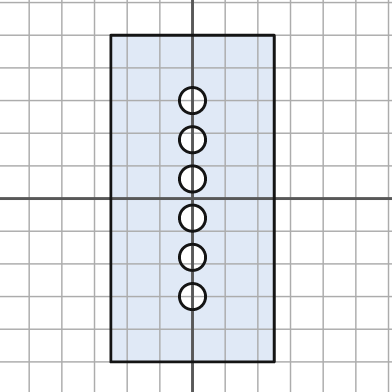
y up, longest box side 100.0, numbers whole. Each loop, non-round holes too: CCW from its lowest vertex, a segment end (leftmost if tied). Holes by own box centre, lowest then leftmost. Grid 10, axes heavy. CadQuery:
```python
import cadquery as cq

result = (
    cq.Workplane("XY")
    .moveTo(-25.0, -50.0)
    .lineTo(25.0, -50.0)
    .lineTo(25.0, 50.0)
    .lineTo(-25.0, 50.0)
    .close()
    .moveTo(0.0, -30.0)
    .circle(4.0)
    .moveTo(0.0, -18.0)
    .circle(4.0)
    .moveTo(0.0, -6.0)
    .circle(4.0)
    .moveTo(0.0, 6.0)
    .circle(4.0)
    .moveTo(0.0, 18.0)
    .circle(4.0)
    .moveTo(0.0, 30.0)
    .circle(4.0)
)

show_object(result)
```